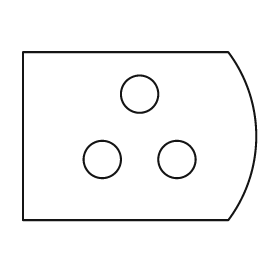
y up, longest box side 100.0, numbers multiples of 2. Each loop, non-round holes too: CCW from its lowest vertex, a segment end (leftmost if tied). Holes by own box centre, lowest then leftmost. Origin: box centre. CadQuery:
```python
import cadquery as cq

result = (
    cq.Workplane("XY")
    .moveTo(-50.0, -36.0)
    .lineTo(38.0, -36.0)
    .threePointArc((50.0, 0.0), (38.0, 36.0))
    .lineTo(-50.0, 36.0)
    .close()
    .moveTo(-16.0, -10.0)
    .circle(8.0)
    .moveTo(16.0, -10.0)
    .circle(8.0)
    .moveTo(0.0, 18.0)
    .circle(8.0)
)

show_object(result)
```